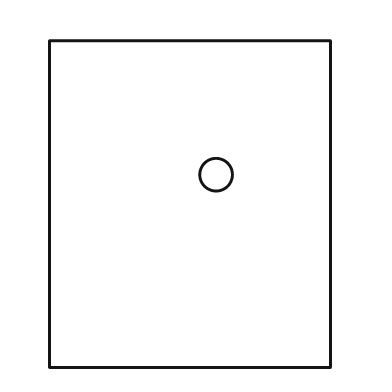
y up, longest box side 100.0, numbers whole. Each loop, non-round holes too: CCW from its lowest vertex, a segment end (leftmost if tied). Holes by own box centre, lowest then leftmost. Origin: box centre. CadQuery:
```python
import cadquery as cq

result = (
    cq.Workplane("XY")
    .moveTo(-43.0, -50.0)
    .lineTo(43.0, -50.0)
    .lineTo(43.0, 50.0)
    .lineTo(-43.0, 50.0)
    .close()
    .moveTo(8.0, 9.0)
    .circle(5.0)
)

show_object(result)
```